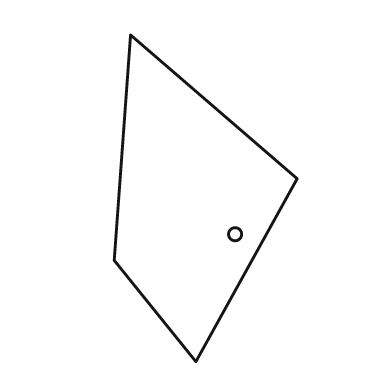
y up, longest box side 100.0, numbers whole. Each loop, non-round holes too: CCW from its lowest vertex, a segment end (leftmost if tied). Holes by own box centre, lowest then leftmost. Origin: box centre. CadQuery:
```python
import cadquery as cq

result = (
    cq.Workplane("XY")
    .moveTo(-3.0, -50.0)
    .lineTo(28.0, 6.0)
    .lineTo(-23.0, 50.0)
    .lineTo(-28.0, -19.0)
    .close()
    .moveTo(9.0, -11.0)
    .circle(2.0)
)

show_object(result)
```